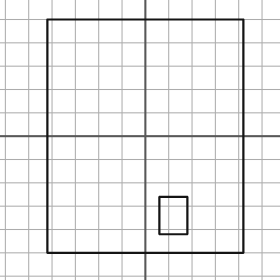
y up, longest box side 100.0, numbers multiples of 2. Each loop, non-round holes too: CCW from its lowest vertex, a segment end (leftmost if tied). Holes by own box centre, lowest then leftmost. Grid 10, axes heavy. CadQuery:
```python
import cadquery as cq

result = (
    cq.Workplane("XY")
    .moveTo(-42.0, -50.0)
    .lineTo(42.0, -50.0)
    .lineTo(42.0, 50.0)
    .lineTo(-42.0, 50.0)
    .close()
    .moveTo(6.0, -42.0)
    .lineTo(18.0, -42.0)
    .lineTo(18.0, -26.0)
    .lineTo(6.0, -26.0)
    .close()
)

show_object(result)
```